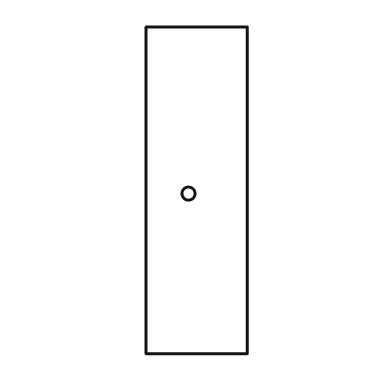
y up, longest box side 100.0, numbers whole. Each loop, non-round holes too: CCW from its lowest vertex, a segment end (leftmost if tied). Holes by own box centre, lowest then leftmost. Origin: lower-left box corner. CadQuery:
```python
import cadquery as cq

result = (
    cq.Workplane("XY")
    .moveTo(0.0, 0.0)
    .lineTo(31.0, 0.0)
    .lineTo(31.0, 100.0)
    .lineTo(0.0, 100.0)
    .close()
    .moveTo(13.0, 49.0)
    .circle(2.0)
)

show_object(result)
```